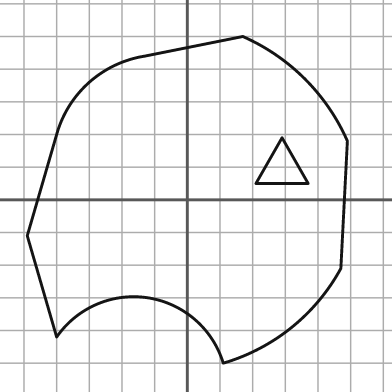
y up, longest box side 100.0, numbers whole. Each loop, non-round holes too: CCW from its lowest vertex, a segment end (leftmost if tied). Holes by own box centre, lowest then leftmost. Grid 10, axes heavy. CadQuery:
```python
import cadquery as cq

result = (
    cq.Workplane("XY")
    .moveTo(11.0, -50.0)
    .threePointArc((32.0, -39.0), (47.0, -21.0))
    .lineTo(49.0, 18.0)
    .threePointArc((36.0, 37.0), (17.0, 50.0))
    .lineTo(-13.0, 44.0)
    .threePointArc((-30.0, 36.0), (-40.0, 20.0))
    .lineTo(-49.0, -11.0)
    .lineTo(-40.0, -42.0)
    .threePointArc((-12.0, -30.0), (11.0, -50.0))
    .close()
    .moveTo(21.0, 5.0)
    .lineTo(37.0, 5.0)
    .lineTo(29.0, 19.0)
    .close()
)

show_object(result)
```